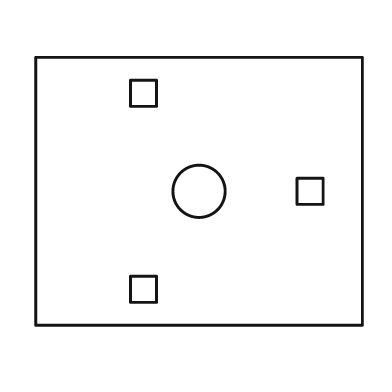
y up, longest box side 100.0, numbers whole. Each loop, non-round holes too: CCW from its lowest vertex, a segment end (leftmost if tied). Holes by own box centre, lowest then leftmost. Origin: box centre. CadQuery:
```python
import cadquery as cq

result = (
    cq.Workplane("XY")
    .moveTo(-50.0, -41.0)
    .lineTo(50.0, -41.0)
    .lineTo(50.0, 41.0)
    .lineTo(-50.0, 41.0)
    .close()
    .moveTo(-21.0, -34.0)
    .lineTo(-13.0, -34.0)
    .lineTo(-13.0, -26.0)
    .lineTo(-21.0, -26.0)
    .close()
    .moveTo(0.0, 0.0)
    .circle(8.0)
    .moveTo(30.0, -4.0)
    .lineTo(38.0, -4.0)
    .lineTo(38.0, 4.0)
    .lineTo(30.0, 4.0)
    .close()
    .moveTo(-21.0, 26.0)
    .lineTo(-13.0, 26.0)
    .lineTo(-13.0, 34.0)
    .lineTo(-21.0, 34.0)
    .close()
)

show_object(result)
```